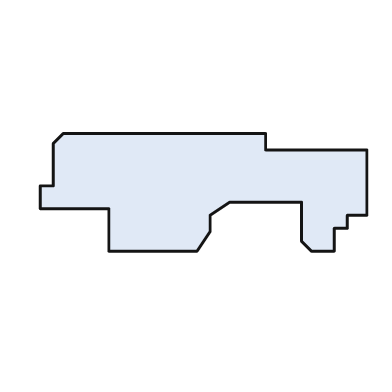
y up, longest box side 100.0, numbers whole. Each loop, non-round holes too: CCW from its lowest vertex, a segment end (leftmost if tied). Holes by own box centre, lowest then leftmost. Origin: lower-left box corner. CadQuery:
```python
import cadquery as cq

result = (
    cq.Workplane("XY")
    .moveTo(21.0, 0.0)
    .lineTo(48.0, 0.0)
    .lineTo(52.0, 6.0)
    .lineTo(52.0, 11.0)
    .lineTo(58.0, 15.0)
    .lineTo(80.0, 15.0)
    .lineTo(80.0, 3.0)
    .lineTo(83.0, 0.0)
    .lineTo(90.0, 0.0)
    .lineTo(90.0, 7.0)
    .lineTo(94.0, 7.0)
    .lineTo(94.0, 11.0)
    .lineTo(100.0, 11.0)
    .lineTo(100.0, 31.0)
    .lineTo(69.0, 31.0)
    .lineTo(69.0, 36.0)
    .lineTo(7.0, 36.0)
    .lineTo(4.0, 33.0)
    .lineTo(4.0, 20.0)
    .lineTo(0.0, 20.0)
    .lineTo(0.0, 13.0)
    .lineTo(21.0, 13.0)
    .close()
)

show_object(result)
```